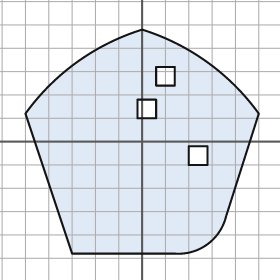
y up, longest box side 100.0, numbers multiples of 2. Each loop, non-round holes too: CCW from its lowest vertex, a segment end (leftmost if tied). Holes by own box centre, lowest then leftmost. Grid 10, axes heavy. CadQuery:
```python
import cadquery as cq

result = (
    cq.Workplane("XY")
    .moveTo(-30.0, -48.0)
    .lineTo(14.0, -48.0)
    .threePointArc((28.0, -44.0), (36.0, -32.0))
    .lineTo(50.0, 12.0)
    .threePointArc((28.0, 34.0), (0.0, 48.0))
    .threePointArc((-28.0, 34.0), (-50.0, 12.0))
    .close()
    .moveTo(20.0, -10.0)
    .lineTo(28.0, -10.0)
    .lineTo(28.0, -2.0)
    .lineTo(20.0, -2.0)
    .close()
    .moveTo(-2.0, 10.0)
    .lineTo(6.0, 10.0)
    .lineTo(6.0, 18.0)
    .lineTo(-2.0, 18.0)
    .close()
    .moveTo(6.0, 24.0)
    .lineTo(14.0, 24.0)
    .lineTo(14.0, 32.0)
    .lineTo(6.0, 32.0)
    .close()
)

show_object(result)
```